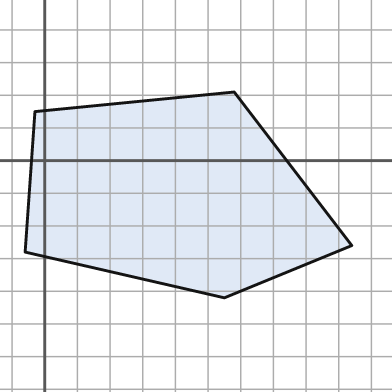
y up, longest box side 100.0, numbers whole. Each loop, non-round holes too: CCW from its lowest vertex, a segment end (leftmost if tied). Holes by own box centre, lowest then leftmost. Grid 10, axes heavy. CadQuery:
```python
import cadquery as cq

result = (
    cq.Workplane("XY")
    .moveTo(55.0, -42.0)
    .lineTo(94.0, -26.0)
    .lineTo(58.0, 21.0)
    .lineTo(-3.0, 15.0)
    .lineTo(-6.0, -28.0)
    .close()
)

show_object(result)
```